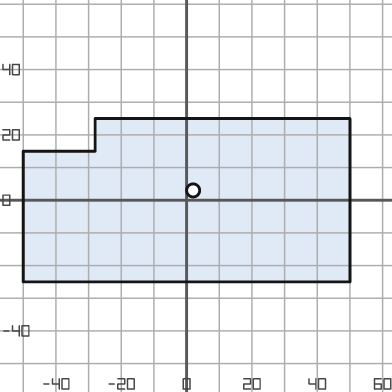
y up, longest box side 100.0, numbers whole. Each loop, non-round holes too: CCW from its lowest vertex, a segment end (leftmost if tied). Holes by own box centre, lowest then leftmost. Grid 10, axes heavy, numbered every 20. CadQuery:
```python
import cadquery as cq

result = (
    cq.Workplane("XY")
    .moveTo(-50.0, -25.0)
    .lineTo(50.0, -25.0)
    .lineTo(50.0, 25.0)
    .lineTo(-28.0, 25.0)
    .lineTo(-28.0, 15.0)
    .lineTo(-50.0, 15.0)
    .close()
    .moveTo(2.0, 3.0)
    .circle(2.0)
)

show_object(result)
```